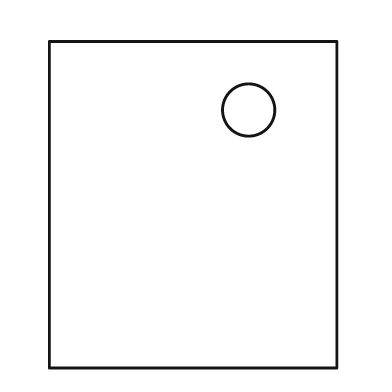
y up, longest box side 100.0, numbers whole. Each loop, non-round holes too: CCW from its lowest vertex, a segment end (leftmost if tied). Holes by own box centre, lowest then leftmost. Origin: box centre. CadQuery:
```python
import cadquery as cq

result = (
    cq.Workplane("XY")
    .moveTo(-44.0, -50.0)
    .lineTo(44.0, -50.0)
    .lineTo(44.0, 50.0)
    .lineTo(-44.0, 50.0)
    .close()
    .moveTo(17.0, 29.0)
    .circle(8.0)
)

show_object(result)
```